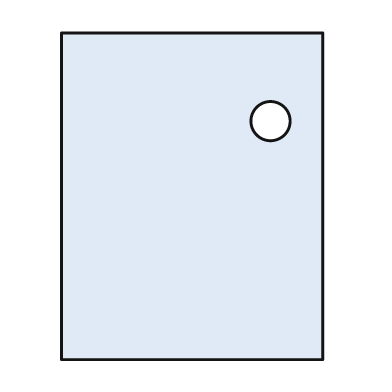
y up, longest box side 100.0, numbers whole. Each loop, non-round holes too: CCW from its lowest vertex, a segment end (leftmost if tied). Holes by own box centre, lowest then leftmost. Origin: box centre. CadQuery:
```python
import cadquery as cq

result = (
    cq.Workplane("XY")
    .moveTo(-40.0, -50.0)
    .lineTo(40.0, -50.0)
    .lineTo(40.0, 50.0)
    .lineTo(-40.0, 50.0)
    .close()
    .moveTo(24.0, 23.0)
    .circle(6.0)
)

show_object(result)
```